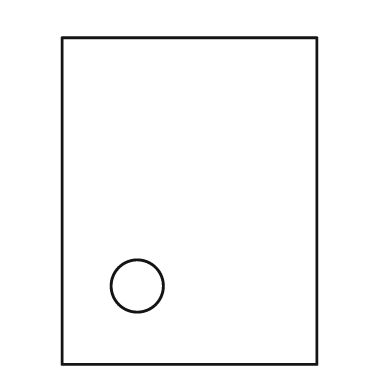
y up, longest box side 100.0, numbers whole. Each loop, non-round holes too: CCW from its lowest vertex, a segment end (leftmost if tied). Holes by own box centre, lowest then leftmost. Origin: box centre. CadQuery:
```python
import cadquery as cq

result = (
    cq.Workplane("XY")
    .moveTo(-39.0, -50.0)
    .lineTo(39.0, -50.0)
    .lineTo(39.0, 50.0)
    .lineTo(-39.0, 50.0)
    .close()
    .moveTo(-16.0, -26.0)
    .circle(8.0)
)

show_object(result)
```